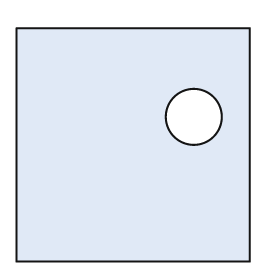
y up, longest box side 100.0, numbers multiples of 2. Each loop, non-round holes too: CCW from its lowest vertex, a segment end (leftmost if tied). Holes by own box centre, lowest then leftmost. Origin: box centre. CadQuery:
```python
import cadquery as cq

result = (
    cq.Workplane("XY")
    .moveTo(-50.0, -50.0)
    .lineTo(50.0, -50.0)
    .lineTo(50.0, 50.0)
    .lineTo(-50.0, 50.0)
    .close()
    .moveTo(26.0, 12.0)
    .circle(12.0)
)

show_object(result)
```